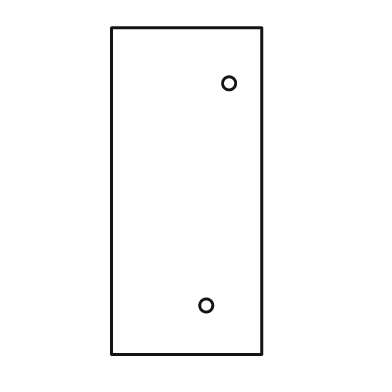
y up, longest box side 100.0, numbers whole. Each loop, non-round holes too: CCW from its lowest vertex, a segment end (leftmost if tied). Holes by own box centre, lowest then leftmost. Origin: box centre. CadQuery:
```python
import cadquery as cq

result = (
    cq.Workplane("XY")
    .moveTo(-23.0, -50.0)
    .lineTo(23.0, -50.0)
    .lineTo(23.0, 50.0)
    .lineTo(-23.0, 50.0)
    .close()
    .moveTo(6.0, -35.0)
    .circle(2.0)
    .moveTo(13.0, 33.0)
    .circle(2.0)
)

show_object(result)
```